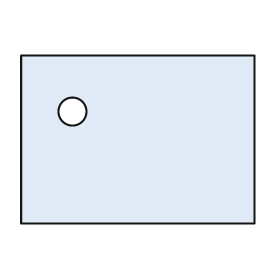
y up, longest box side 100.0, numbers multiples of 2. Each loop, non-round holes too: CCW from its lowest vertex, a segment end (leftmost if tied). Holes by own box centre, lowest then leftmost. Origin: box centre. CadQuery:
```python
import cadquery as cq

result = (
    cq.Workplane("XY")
    .moveTo(-50.0, -36.0)
    .lineTo(50.0, -36.0)
    .lineTo(50.0, 36.0)
    .lineTo(-50.0, 36.0)
    .close()
    .moveTo(-28.0, 12.0)
    .circle(6.0)
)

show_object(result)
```